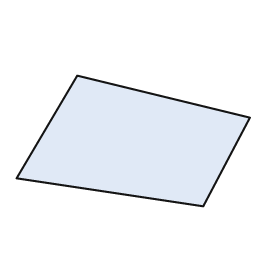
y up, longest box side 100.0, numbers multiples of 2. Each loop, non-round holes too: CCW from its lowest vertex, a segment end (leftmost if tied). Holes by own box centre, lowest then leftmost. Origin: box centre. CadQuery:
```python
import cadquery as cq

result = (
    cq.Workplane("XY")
    .moveTo(30.0, -28.0)
    .lineTo(50.0, 10.0)
    .lineTo(-24.0, 28.0)
    .lineTo(-50.0, -16.0)
    .close()
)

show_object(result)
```